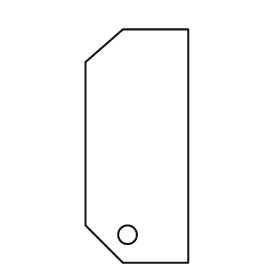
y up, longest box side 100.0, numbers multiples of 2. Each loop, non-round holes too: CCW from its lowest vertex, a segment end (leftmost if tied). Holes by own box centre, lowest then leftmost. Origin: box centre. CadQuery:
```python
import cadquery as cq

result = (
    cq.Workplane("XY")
    .moveTo(-6.0, -50.0)
    .lineTo(22.0, -50.0)
    .lineTo(22.0, 50.0)
    .lineTo(-6.0, 50.0)
    .lineTo(-22.0, 36.0)
    .lineTo(-22.0, -34.0)
    .close()
    .moveTo(-4.0, -38.0)
    .circle(4.0)
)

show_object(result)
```